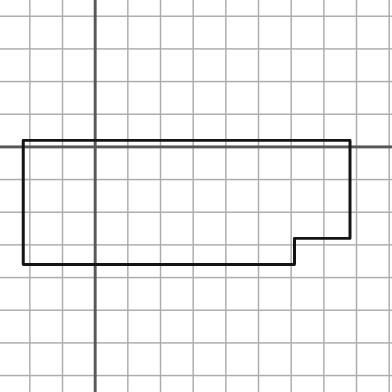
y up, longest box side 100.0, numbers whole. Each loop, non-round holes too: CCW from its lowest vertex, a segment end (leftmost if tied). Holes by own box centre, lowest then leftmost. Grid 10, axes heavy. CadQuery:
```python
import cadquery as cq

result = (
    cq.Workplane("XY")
    .moveTo(-22.0, -36.0)
    .lineTo(61.0, -36.0)
    .lineTo(61.0, -28.0)
    .lineTo(78.0, -28.0)
    .lineTo(78.0, 2.0)
    .lineTo(-22.0, 2.0)
    .close()
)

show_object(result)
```